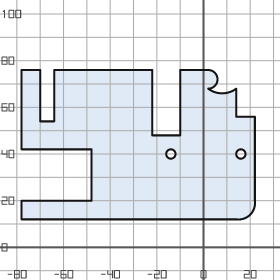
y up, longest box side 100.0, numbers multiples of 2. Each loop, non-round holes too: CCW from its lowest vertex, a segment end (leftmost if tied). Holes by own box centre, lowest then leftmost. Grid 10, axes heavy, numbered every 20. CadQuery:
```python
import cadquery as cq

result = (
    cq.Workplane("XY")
    .moveTo(-78.0, 12.0)
    .lineTo(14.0, 12.0)
    .threePointArc((20.0, 14.0), (22.0, 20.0))
    .lineTo(22.0, 56.0)
    .lineTo(14.0, 56.0)
    .lineTo(14.0, 68.0)
    .threePointArc((8.0, 66.0), (2.0, 68.0))
    .threePointArc((6.0, 72.0), (2.0, 76.0))
    .lineTo(-10.0, 76.0)
    .lineTo(-10.0, 48.0)
    .lineTo(-22.0, 48.0)
    .lineTo(-22.0, 76.0)
    .lineTo(-64.0, 76.0)
    .lineTo(-64.0, 54.0)
    .lineTo(-70.0, 54.0)
    .lineTo(-70.0, 76.0)
    .lineTo(-78.0, 76.0)
    .lineTo(-78.0, 42.0)
    .lineTo(-48.0, 42.0)
    .lineTo(-48.0, 20.0)
    .lineTo(-78.0, 20.0)
    .close()
    .moveTo(-14.0, 40.0)
    .circle(2.0)
    .moveTo(16.0, 40.0)
    .circle(2.0)
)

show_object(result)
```